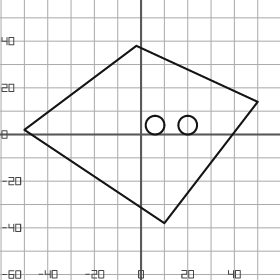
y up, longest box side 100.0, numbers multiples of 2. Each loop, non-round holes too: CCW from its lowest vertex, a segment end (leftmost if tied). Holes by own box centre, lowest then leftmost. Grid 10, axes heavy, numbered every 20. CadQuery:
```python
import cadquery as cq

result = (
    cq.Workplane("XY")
    .moveTo(10.0, -38.0)
    .lineTo(50.0, 14.0)
    .lineTo(-2.0, 38.0)
    .lineTo(-50.0, 2.0)
    .close()
    .moveTo(6.0, 4.0)
    .circle(4.0)
    .moveTo(20.0, 4.0)
    .circle(4.0)
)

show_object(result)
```